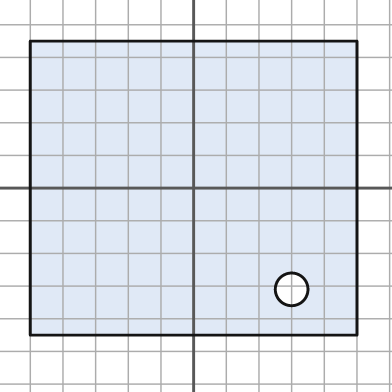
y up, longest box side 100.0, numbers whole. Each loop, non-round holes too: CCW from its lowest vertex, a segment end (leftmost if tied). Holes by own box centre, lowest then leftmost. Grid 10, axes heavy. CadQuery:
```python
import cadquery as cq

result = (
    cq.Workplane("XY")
    .moveTo(-50.0, -45.0)
    .lineTo(50.0, -45.0)
    .lineTo(50.0, 45.0)
    .lineTo(-50.0, 45.0)
    .close()
    .moveTo(30.0, -31.0)
    .circle(5.0)
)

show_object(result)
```